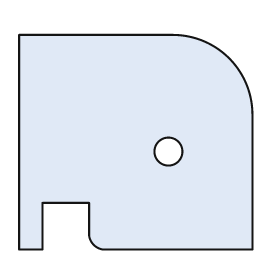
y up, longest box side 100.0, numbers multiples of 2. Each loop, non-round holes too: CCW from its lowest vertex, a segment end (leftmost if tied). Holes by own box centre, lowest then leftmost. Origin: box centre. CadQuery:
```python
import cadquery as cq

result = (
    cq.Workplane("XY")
    .moveTo(-50.0, -46.0)
    .lineTo(-40.0, -46.0)
    .lineTo(-40.0, -26.0)
    .lineTo(-20.0, -26.0)
    .lineTo(-20.0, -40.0)
    .threePointArc((-18.0, -44.0), (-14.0, -46.0))
    .lineTo(50.0, -46.0)
    .lineTo(50.0, 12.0)
    .threePointArc((40.0, 36.0), (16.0, 46.0))
    .lineTo(-50.0, 46.0)
    .close()
    .moveTo(14.0, -4.0)
    .circle(6.0)
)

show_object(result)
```